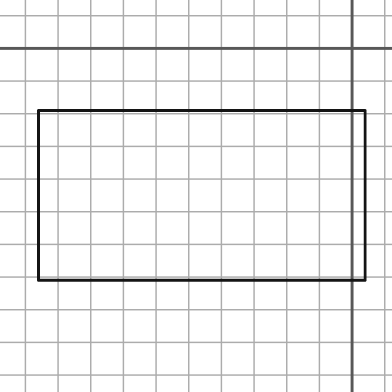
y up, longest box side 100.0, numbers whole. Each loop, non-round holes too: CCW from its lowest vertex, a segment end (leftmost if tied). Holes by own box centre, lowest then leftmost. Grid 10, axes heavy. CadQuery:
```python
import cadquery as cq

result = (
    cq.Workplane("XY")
    .moveTo(-96.0, -71.0)
    .lineTo(4.0, -71.0)
    .lineTo(4.0, -19.0)
    .lineTo(-96.0, -19.0)
    .close()
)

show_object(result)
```